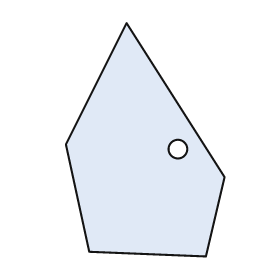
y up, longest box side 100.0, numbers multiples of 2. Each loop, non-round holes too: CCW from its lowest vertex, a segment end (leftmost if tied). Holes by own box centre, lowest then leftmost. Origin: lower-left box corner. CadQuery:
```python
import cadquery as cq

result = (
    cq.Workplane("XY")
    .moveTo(60.0, 0.0)
    .lineTo(68.0, 34.0)
    .lineTo(26.0, 100.0)
    .lineTo(0.0, 48.0)
    .lineTo(10.0, 2.0)
    .close()
    .moveTo(48.0, 46.0)
    .circle(4.0)
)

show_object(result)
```